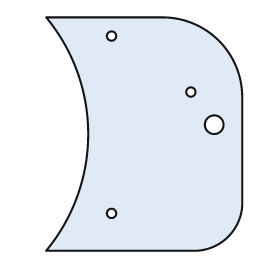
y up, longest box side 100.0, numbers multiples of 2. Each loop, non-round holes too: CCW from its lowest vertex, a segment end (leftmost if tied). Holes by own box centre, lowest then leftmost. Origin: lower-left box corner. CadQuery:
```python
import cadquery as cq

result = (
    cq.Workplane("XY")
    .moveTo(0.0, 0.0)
    .lineTo(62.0, 0.0)
    .threePointArc((78.0, 6.0), (84.0, 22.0))
    .lineTo(84.0, 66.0)
    .threePointArc((74.0, 90.0), (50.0, 100.0))
    .lineTo(0.0, 100.0)
    .threePointArc((18.0, 50.0), (0.0, 0.0))
    .close()
    .moveTo(28.0, 16.0)
    .circle(2.0)
    .moveTo(72.0, 54.0)
    .circle(4.0)
    .moveTo(62.0, 68.0)
    .circle(2.0)
    .moveTo(28.0, 92.0)
    .circle(2.0)
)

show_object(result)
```